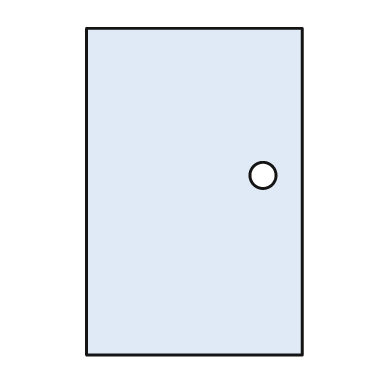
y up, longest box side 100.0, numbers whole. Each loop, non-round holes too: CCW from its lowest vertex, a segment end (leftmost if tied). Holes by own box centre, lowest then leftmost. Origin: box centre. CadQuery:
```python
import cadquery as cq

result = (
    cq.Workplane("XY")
    .moveTo(-33.0, -50.0)
    .lineTo(33.0, -50.0)
    .lineTo(33.0, 50.0)
    .lineTo(-33.0, 50.0)
    .close()
    .moveTo(21.0, 5.0)
    .circle(4.0)
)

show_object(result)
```